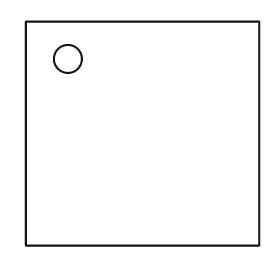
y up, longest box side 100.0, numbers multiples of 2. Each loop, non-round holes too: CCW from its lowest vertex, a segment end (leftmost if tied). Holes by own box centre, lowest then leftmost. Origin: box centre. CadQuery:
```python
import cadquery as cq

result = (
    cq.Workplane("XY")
    .moveTo(-50.0, -48.0)
    .lineTo(50.0, -48.0)
    .lineTo(50.0, 48.0)
    .lineTo(-50.0, 48.0)
    .close()
    .moveTo(-32.0, 32.0)
    .circle(6.0)
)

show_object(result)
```